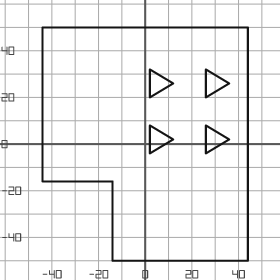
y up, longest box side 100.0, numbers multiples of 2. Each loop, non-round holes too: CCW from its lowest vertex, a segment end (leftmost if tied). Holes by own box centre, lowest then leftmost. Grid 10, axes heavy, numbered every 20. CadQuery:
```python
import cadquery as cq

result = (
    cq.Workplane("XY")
    .moveTo(-14.0, -50.0)
    .lineTo(44.0, -50.0)
    .lineTo(44.0, 50.0)
    .lineTo(-44.0, 50.0)
    .lineTo(-44.0, -16.0)
    .lineTo(-14.0, -16.0)
    .close()
    .moveTo(2.0, -4.0)
    .lineTo(12.0, 2.0)
    .lineTo(2.0, 8.0)
    .close()
    .moveTo(26.0, -4.0)
    .lineTo(36.0, 2.0)
    .lineTo(26.0, 8.0)
    .close()
    .moveTo(2.0, 20.0)
    .lineTo(12.0, 26.0)
    .lineTo(2.0, 32.0)
    .close()
    .moveTo(26.0, 20.0)
    .lineTo(36.0, 26.0)
    .lineTo(26.0, 32.0)
    .close()
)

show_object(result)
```